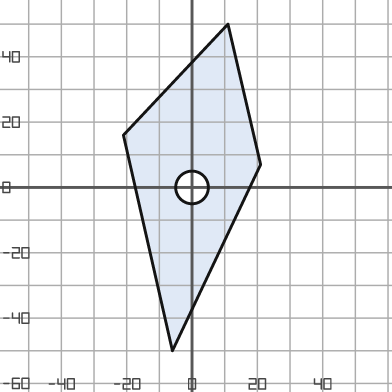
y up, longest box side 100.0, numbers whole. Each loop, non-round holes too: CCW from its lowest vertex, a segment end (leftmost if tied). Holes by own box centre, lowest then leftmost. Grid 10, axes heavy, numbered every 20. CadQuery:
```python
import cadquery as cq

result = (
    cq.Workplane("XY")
    .moveTo(-6.0, -50.0)
    .lineTo(21.0, 7.0)
    .lineTo(11.0, 50.0)
    .lineTo(-21.0, 16.0)
    .close()
    .moveTo(0.0, 0.0)
    .circle(5.0)
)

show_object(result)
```